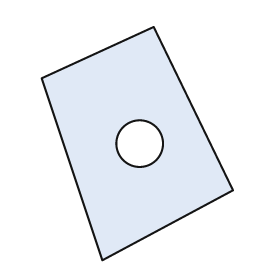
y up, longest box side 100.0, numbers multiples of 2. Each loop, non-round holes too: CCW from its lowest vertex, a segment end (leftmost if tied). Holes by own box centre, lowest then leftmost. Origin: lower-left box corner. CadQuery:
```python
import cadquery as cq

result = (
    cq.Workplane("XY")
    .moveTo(26.0, 0.0)
    .lineTo(82.0, 30.0)
    .lineTo(48.0, 100.0)
    .lineTo(0.0, 78.0)
    .close()
    .moveTo(42.0, 50.0)
    .circle(10.0)
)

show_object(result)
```